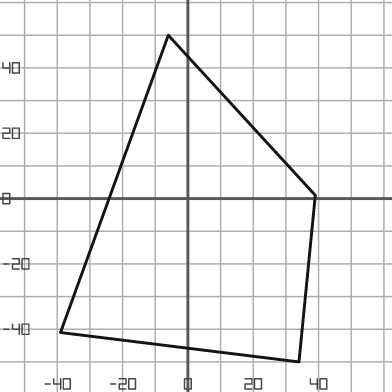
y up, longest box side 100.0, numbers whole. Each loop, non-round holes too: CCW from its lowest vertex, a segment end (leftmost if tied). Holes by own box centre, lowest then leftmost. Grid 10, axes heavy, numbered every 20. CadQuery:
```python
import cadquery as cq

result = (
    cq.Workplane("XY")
    .moveTo(34.0, -50.0)
    .lineTo(39.0, 1.0)
    .lineTo(-6.0, 50.0)
    .lineTo(-39.0, -41.0)
    .close()
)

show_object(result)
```